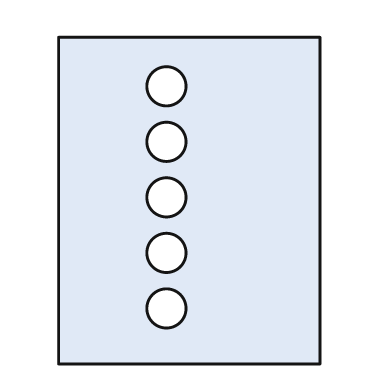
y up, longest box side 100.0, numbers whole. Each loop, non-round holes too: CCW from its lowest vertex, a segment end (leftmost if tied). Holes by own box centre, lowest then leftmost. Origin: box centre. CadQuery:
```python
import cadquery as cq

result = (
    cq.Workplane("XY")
    .moveTo(-40.0, -50.0)
    .lineTo(40.0, -50.0)
    .lineTo(40.0, 50.0)
    .lineTo(-40.0, 50.0)
    .close()
    .moveTo(-7.0, -33.0)
    .circle(6.0)
    .moveTo(-7.0, -16.0)
    .circle(6.0)
    .moveTo(-7.0, 1.0)
    .circle(6.0)
    .moveTo(-7.0, 18.0)
    .circle(6.0)
    .moveTo(-7.0, 35.0)
    .circle(6.0)
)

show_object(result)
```